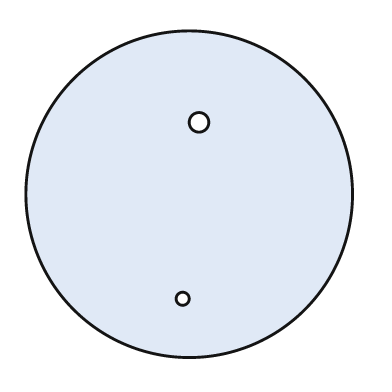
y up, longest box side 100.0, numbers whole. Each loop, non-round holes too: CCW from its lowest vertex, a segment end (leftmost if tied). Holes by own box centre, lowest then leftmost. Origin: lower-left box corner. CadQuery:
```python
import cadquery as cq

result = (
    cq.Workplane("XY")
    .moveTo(50.0, 50.0)
    .circle(50.0)
    .moveTo(48.0, 18.0)
    .circle(2.0)
    .moveTo(53.0, 72.0)
    .circle(3.0)
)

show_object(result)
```